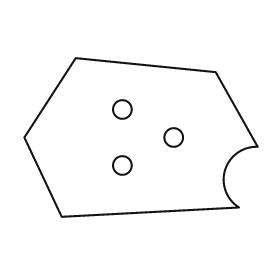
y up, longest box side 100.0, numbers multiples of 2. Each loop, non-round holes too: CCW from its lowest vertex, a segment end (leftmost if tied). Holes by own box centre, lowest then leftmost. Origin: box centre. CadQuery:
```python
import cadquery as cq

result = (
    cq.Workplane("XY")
    .moveTo(-34.0, -34.0)
    .lineTo(42.0, -30.0)
    .threePointArc((36.0, -14.0), (50.0, -4.0))
    .lineTo(32.0, 28.0)
    .lineTo(-28.0, 34.0)
    .lineTo(-50.0, 0.0)
    .close()
    .moveTo(-8.0, -12.0)
    .circle(4.0)
    .moveTo(14.0, 0.0)
    .circle(4.0)
    .moveTo(-8.0, 12.0)
    .circle(4.0)
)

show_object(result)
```